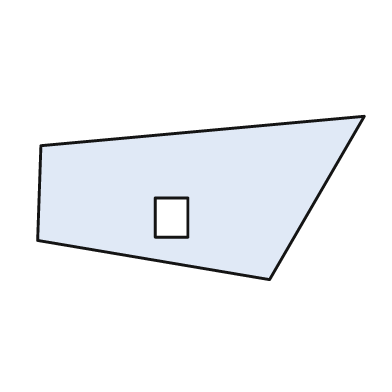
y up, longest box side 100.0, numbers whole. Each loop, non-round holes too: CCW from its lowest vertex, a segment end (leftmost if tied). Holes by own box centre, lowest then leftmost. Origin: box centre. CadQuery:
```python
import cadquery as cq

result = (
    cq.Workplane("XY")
    .moveTo(21.0, -25.0)
    .lineTo(50.0, 25.0)
    .lineTo(-49.0, 16.0)
    .lineTo(-50.0, -13.0)
    .close()
    .moveTo(-14.0, -12.0)
    .lineTo(-4.0, -12.0)
    .lineTo(-4.0, 0.0)
    .lineTo(-14.0, 0.0)
    .close()
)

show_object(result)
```